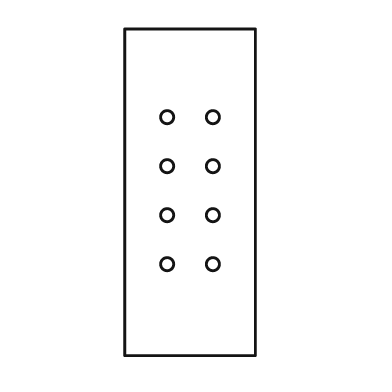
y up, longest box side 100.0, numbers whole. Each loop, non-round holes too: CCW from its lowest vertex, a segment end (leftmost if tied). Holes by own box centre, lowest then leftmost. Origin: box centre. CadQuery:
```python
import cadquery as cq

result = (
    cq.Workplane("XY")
    .moveTo(-20.0, -50.0)
    .lineTo(20.0, -50.0)
    .lineTo(20.0, 50.0)
    .lineTo(-20.0, 50.0)
    .close()
    .moveTo(-7.0, -22.0)
    .circle(2.0)
    .moveTo(7.0, -22.0)
    .circle(2.0)
    .moveTo(-7.0, -7.0)
    .circle(2.0)
    .moveTo(7.0, -7.0)
    .circle(2.0)
    .moveTo(-7.0, 8.0)
    .circle(2.0)
    .moveTo(7.0, 8.0)
    .circle(2.0)
    .moveTo(-7.0, 23.0)
    .circle(2.0)
    .moveTo(7.0, 23.0)
    .circle(2.0)
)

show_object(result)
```